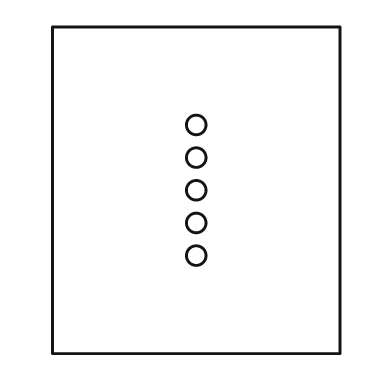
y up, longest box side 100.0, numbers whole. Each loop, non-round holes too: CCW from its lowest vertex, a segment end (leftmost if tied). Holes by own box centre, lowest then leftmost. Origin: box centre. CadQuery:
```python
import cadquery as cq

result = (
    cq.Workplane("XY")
    .moveTo(-44.0, -50.0)
    .lineTo(44.0, -50.0)
    .lineTo(44.0, 50.0)
    .lineTo(-44.0, 50.0)
    .close()
    .moveTo(0.0, -20.0)
    .circle(3.0)
    .moveTo(0.0, -10.0)
    .circle(3.0)
    .moveTo(0.0, 0.0)
    .circle(3.0)
    .moveTo(0.0, 10.0)
    .circle(3.0)
    .moveTo(0.0, 20.0)
    .circle(3.0)
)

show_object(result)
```